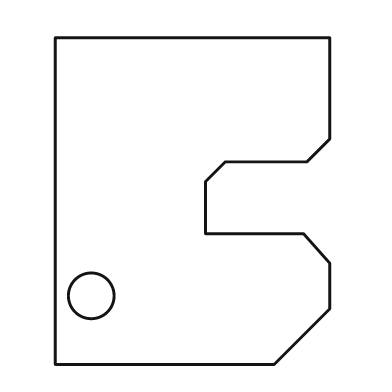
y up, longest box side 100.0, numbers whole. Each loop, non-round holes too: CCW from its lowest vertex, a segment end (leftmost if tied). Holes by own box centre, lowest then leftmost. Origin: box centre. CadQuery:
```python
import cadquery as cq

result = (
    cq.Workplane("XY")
    .moveTo(-42.0, -50.0)
    .lineTo(25.0, -50.0)
    .lineTo(42.0, -33.0)
    .lineTo(42.0, -19.0)
    .lineTo(34.0, -10.0)
    .lineTo(4.0, -10.0)
    .lineTo(4.0, 6.0)
    .lineTo(10.0, 12.0)
    .lineTo(35.0, 12.0)
    .lineTo(42.0, 19.0)
    .lineTo(42.0, 50.0)
    .lineTo(-42.0, 50.0)
    .close()
    .moveTo(-31.0, -29.0)
    .circle(7.0)
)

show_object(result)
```